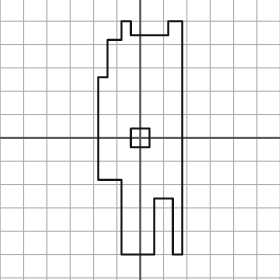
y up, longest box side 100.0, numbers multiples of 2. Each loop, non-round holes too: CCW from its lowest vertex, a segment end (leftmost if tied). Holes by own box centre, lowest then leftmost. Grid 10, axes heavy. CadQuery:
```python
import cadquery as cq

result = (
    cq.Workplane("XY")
    .moveTo(-8.0, -50.0)
    .lineTo(6.0, -50.0)
    .lineTo(6.0, -26.0)
    .lineTo(14.0, -26.0)
    .lineTo(14.0, -50.0)
    .lineTo(18.0, -50.0)
    .lineTo(18.0, 50.0)
    .lineTo(12.0, 50.0)
    .lineTo(12.0, 44.0)
    .lineTo(-4.0, 44.0)
    .lineTo(-4.0, 50.0)
    .lineTo(-8.0, 50.0)
    .lineTo(-8.0, 42.0)
    .lineTo(-14.0, 42.0)
    .lineTo(-14.0, 26.0)
    .lineTo(-18.0, 26.0)
    .lineTo(-18.0, -18.0)
    .lineTo(-8.0, -18.0)
    .close()
    .moveTo(-4.0, -4.0)
    .lineTo(4.0, -4.0)
    .lineTo(4.0, 4.0)
    .lineTo(-4.0, 4.0)
    .close()
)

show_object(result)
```